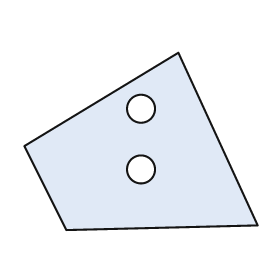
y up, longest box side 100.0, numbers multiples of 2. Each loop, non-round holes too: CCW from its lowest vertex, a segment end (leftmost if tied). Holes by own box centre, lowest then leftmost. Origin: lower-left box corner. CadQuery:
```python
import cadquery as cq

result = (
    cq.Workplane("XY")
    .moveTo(18.0, 0.0)
    .lineTo(100.0, 2.0)
    .lineTo(66.0, 76.0)
    .lineTo(0.0, 36.0)
    .close()
    .moveTo(50.0, 26.0)
    .circle(6.0)
    .moveTo(50.0, 52.0)
    .circle(6.0)
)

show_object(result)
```